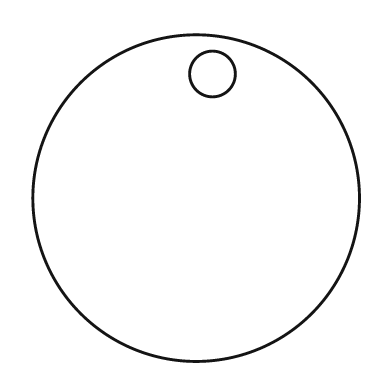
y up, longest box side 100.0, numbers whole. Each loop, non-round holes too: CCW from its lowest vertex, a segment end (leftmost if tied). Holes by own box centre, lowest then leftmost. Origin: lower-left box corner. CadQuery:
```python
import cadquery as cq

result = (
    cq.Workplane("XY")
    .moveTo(50.0, 50.0)
    .circle(50.0)
    .moveTo(55.0, 88.0)
    .circle(7.0)
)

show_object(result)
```